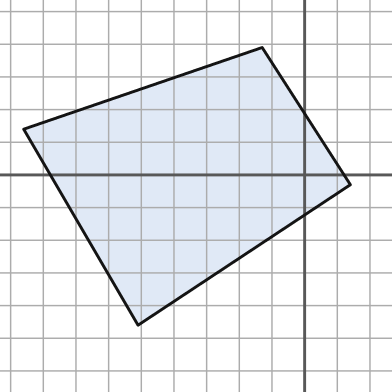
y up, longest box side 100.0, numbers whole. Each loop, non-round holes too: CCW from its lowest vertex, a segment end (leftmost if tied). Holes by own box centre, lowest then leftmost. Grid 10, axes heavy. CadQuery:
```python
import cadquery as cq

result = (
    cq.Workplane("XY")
    .moveTo(-51.0, -46.0)
    .lineTo(14.0, -3.0)
    .lineTo(-13.0, 39.0)
    .lineTo(-86.0, 14.0)
    .close()
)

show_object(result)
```